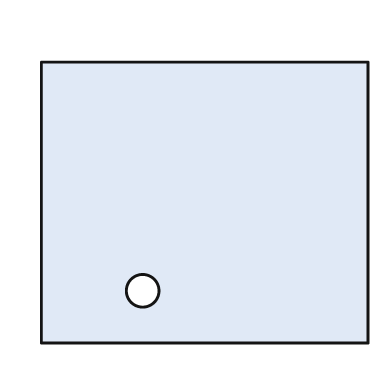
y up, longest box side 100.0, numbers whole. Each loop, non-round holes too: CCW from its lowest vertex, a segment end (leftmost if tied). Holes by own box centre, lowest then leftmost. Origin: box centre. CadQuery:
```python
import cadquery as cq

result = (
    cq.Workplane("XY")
    .moveTo(-50.0, -43.0)
    .lineTo(50.0, -43.0)
    .lineTo(50.0, 43.0)
    .lineTo(-50.0, 43.0)
    .close()
    .moveTo(-19.0, -27.0)
    .circle(5.0)
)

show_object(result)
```